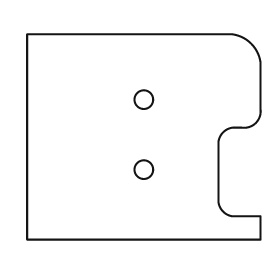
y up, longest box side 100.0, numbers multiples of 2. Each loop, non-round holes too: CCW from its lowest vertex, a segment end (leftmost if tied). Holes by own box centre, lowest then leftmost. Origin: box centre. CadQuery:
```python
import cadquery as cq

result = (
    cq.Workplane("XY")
    .moveTo(-50.0, -44.0)
    .lineTo(50.0, -44.0)
    .lineTo(50.0, -34.0)
    .lineTo(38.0, -34.0)
    .threePointArc((34.0, -32.0), (32.0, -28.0))
    .lineTo(32.0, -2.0)
    .threePointArc((34.0, 2.0), (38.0, 4.0))
    .lineTo(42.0, 4.0)
    .threePointArc((48.0, 6.0), (50.0, 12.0))
    .lineTo(50.0, 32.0)
    .threePointArc((46.0, 40.0), (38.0, 44.0))
    .lineTo(-50.0, 44.0)
    .close()
    .moveTo(0.0, -14.0)
    .circle(4.0)
    .moveTo(0.0, 16.0)
    .circle(4.0)
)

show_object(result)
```